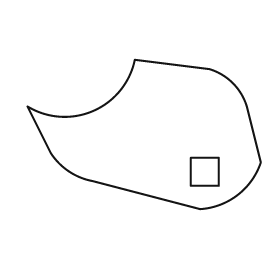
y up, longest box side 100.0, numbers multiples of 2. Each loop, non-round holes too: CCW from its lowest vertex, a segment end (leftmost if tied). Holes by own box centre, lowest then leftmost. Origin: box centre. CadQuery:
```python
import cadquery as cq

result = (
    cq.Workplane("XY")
    .moveTo(24.0, -32.0)
    .threePointArc((40.0, -26.0), (50.0, -12.0))
    .lineTo(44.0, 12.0)
    .threePointArc((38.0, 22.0), (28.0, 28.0))
    .lineTo(-4.0, 32.0)
    .threePointArc((-22.0, 10.0), (-50.0, 12.0))
    .lineTo(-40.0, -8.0)
    .threePointArc((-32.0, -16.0), (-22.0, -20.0))
    .close()
    .moveTo(20.0, -22.0)
    .lineTo(32.0, -22.0)
    .lineTo(32.0, -10.0)
    .lineTo(20.0, -10.0)
    .close()
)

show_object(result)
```